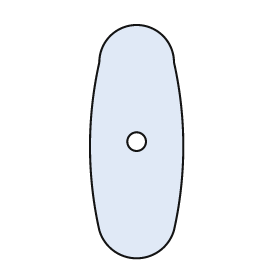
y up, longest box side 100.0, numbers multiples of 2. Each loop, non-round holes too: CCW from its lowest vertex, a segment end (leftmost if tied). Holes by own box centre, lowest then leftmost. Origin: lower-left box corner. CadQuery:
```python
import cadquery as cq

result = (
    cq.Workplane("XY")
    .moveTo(4.0, 12.0)
    .threePointArc((20.0, 0.0), (36.0, 12.0))
    .threePointArc((40.0, 48.0), (36.0, 84.0))
    .threePointArc((20.0, 100.0), (4.0, 84.0))
    .threePointArc((0.0, 48.0), (4.0, 12.0))
    .close()
    .moveTo(20.0, 50.0)
    .circle(4.0)
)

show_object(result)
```